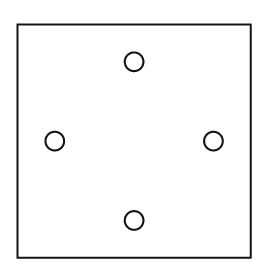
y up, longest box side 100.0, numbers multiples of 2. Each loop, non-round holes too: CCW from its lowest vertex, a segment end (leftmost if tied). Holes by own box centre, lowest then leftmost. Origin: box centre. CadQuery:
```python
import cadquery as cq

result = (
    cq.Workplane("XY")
    .moveTo(-50.0, -50.0)
    .lineTo(50.0, -50.0)
    .lineTo(50.0, 50.0)
    .lineTo(-50.0, 50.0)
    .close()
    .moveTo(0.0, -34.0)
    .circle(4.0)
    .moveTo(-34.0, 0.0)
    .circle(4.0)
    .moveTo(34.0, 0.0)
    .circle(4.0)
    .moveTo(0.0, 34.0)
    .circle(4.0)
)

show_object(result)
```